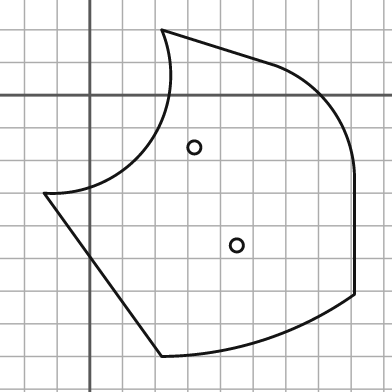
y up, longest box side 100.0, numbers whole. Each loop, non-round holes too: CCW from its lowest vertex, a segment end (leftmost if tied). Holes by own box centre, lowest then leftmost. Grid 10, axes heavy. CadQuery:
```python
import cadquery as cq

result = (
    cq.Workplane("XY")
    .moveTo(22.0, -80.0)
    .threePointArc((53.0, -75.0), (81.0, -61.0))
    .lineTo(81.0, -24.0)
    .threePointArc((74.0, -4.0), (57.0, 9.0))
    .lineTo(22.0, 20.0)
    .threePointArc((18.0, -15.0), (-14.0, -30.0))
    .close()
    .moveTo(45.0, -46.0)
    .circle(2.0)
    .moveTo(32.0, -16.0)
    .circle(2.0)
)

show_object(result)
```